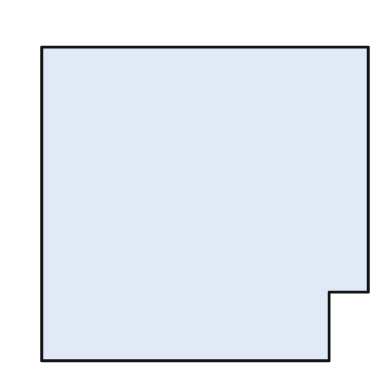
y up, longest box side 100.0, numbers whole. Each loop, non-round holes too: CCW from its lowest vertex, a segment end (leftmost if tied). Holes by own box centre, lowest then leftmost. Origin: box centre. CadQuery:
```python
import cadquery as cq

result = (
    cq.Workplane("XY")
    .moveTo(-50.0, -48.0)
    .lineTo(38.0, -48.0)
    .lineTo(38.0, -27.0)
    .lineTo(50.0, -27.0)
    .lineTo(50.0, 48.0)
    .lineTo(-50.0, 48.0)
    .close()
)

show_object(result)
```